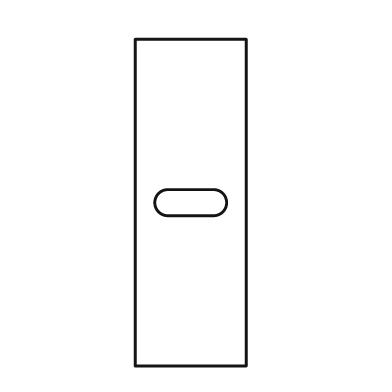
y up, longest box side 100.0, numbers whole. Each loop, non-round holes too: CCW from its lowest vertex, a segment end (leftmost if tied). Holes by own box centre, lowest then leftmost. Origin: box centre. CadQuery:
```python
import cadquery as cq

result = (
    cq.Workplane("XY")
    .moveTo(-17.0, -50.0)
    .lineTo(17.0, -50.0)
    .lineTo(17.0, 50.0)
    .lineTo(-17.0, 50.0)
    .close()
    .moveTo(-7.0, -4.0)
    .lineTo(7.0, -4.0)
    .threePointArc((11.0, 0.0), (7.0, 4.0))
    .lineTo(-7.0, 4.0)
    .threePointArc((-11.0, 0.0), (-7.0, -4.0))
    .close()
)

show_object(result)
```